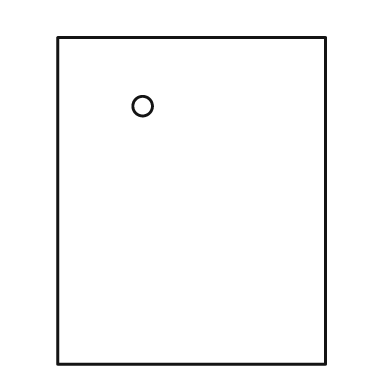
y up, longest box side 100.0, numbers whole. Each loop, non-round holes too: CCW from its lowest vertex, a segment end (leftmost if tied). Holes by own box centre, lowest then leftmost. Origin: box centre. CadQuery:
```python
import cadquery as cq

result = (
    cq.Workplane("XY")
    .moveTo(-41.0, -50.0)
    .lineTo(41.0, -50.0)
    .lineTo(41.0, 50.0)
    .lineTo(-41.0, 50.0)
    .close()
    .moveTo(-15.0, 29.0)
    .circle(3.0)
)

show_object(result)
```